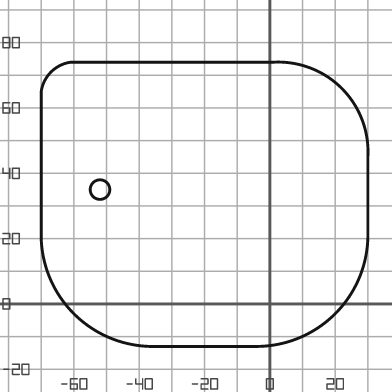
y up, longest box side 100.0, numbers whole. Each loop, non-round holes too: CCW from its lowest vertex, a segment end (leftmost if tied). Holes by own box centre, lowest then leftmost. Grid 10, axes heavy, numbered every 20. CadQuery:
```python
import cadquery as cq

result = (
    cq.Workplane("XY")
    .moveTo(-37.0, -13.0)
    .lineTo(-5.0, -13.0)
    .threePointArc((20.0, -3.0), (30.0, 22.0))
    .lineTo(30.0, 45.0)
    .threePointArc((22.0, 66.0), (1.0, 74.0))
    .lineTo(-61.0, 74.0)
    .threePointArc((-67.0, 71.0), (-70.0, 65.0))
    .lineTo(-70.0, 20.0)
    .threePointArc((-60.0, -3.0), (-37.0, -13.0))
    .close()
    .moveTo(-52.0, 35.0)
    .circle(3.0)
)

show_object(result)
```